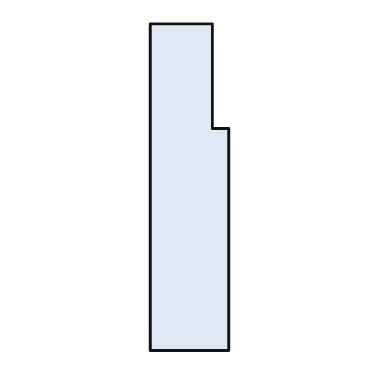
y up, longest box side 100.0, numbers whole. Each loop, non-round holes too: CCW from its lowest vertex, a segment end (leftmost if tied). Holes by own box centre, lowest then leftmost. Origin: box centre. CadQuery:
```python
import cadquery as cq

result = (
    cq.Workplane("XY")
    .moveTo(-12.0, -50.0)
    .lineTo(12.0, -50.0)
    .lineTo(12.0, 18.0)
    .lineTo(7.0, 18.0)
    .lineTo(7.0, 50.0)
    .lineTo(-12.0, 50.0)
    .close()
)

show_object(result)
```